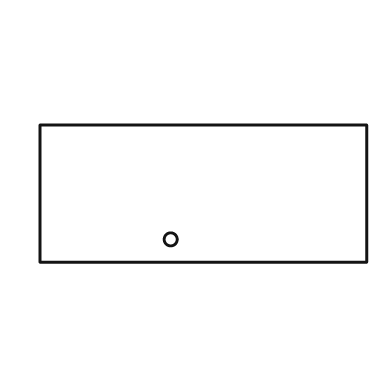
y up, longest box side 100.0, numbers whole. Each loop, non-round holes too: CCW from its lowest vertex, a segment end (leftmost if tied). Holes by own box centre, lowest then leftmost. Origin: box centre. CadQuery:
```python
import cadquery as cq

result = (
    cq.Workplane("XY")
    .moveTo(-50.0, -21.0)
    .lineTo(50.0, -21.0)
    .lineTo(50.0, 21.0)
    .lineTo(-50.0, 21.0)
    .close()
    .moveTo(-10.0, -14.0)
    .circle(2.0)
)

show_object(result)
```